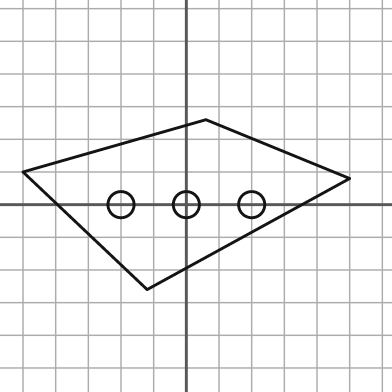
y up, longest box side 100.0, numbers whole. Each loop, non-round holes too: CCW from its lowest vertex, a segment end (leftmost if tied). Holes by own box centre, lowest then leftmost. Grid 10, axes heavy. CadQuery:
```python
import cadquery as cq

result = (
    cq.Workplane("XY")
    .moveTo(-12.0, -26.0)
    .lineTo(50.0, 8.0)
    .lineTo(6.0, 26.0)
    .lineTo(-50.0, 10.0)
    .close()
    .moveTo(-20.0, 0.0)
    .circle(4.0)
    .moveTo(0.0, 0.0)
    .circle(4.0)
    .moveTo(20.0, 0.0)
    .circle(4.0)
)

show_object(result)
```